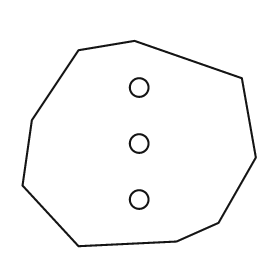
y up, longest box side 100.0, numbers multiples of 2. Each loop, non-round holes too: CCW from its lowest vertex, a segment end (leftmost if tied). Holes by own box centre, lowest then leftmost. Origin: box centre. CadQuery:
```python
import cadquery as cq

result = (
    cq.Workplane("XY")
    .moveTo(-26.0, -44.0)
    .lineTo(16.0, -42.0)
    .lineTo(34.0, -34.0)
    .lineTo(50.0, -6.0)
    .lineTo(44.0, 28.0)
    .lineTo(-2.0, 44.0)
    .lineTo(-26.0, 40.0)
    .lineTo(-46.0, 10.0)
    .lineTo(-50.0, -18.0)
    .close()
    .moveTo(0.0, -24.0)
    .circle(4.0)
    .moveTo(0.0, 0.0)
    .circle(4.0)
    .moveTo(0.0, 24.0)
    .circle(4.0)
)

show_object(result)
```